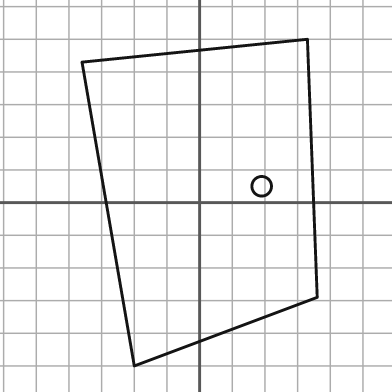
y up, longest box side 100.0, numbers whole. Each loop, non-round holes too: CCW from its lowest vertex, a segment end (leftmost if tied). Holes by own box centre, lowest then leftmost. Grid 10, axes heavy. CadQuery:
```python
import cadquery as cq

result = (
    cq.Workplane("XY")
    .moveTo(-20.0, -50.0)
    .lineTo(36.0, -29.0)
    .lineTo(33.0, 50.0)
    .lineTo(-36.0, 43.0)
    .close()
    .moveTo(19.0, 5.0)
    .circle(3.0)
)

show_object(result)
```